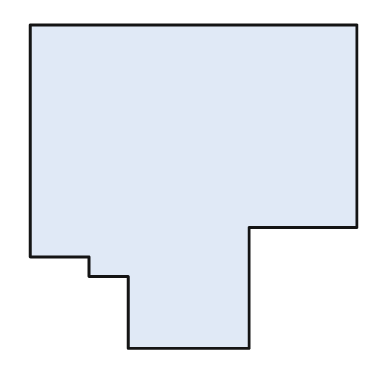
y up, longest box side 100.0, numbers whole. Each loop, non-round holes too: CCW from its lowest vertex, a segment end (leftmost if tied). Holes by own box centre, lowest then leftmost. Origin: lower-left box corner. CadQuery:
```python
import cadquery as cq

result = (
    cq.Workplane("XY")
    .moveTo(30.0, 0.0)
    .lineTo(67.0, 0.0)
    .lineTo(67.0, 37.0)
    .lineTo(100.0, 37.0)
    .lineTo(100.0, 99.0)
    .lineTo(0.0, 99.0)
    .lineTo(0.0, 28.0)
    .lineTo(18.0, 28.0)
    .lineTo(18.0, 22.0)
    .lineTo(30.0, 22.0)
    .close()
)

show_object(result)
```